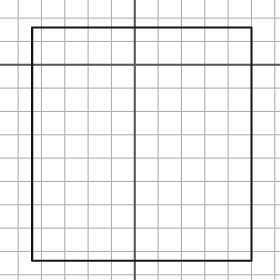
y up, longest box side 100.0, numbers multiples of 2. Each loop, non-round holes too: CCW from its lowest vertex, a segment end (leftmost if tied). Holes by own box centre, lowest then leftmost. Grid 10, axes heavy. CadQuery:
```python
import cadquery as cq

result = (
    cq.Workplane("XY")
    .moveTo(-44.0, -84.0)
    .lineTo(50.0, -84.0)
    .lineTo(50.0, 16.0)
    .lineTo(-44.0, 16.0)
    .close()
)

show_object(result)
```